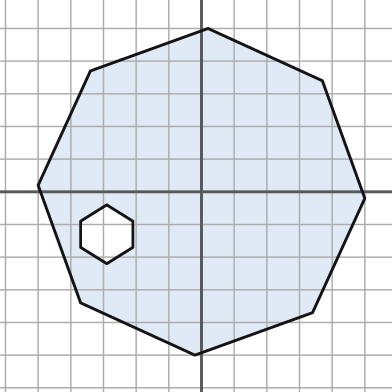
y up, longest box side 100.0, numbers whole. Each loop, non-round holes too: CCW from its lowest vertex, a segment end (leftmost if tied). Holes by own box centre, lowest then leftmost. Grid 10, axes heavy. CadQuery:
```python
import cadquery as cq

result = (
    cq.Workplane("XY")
    .moveTo(-2.0, -50.0)
    .lineTo(34.0, -37.0)
    .lineTo(50.0, -2.0)
    .lineTo(37.0, 34.0)
    .lineTo(2.0, 50.0)
    .lineTo(-34.0, 37.0)
    .lineTo(-50.0, 2.0)
    .lineTo(-37.0, -34.0)
    .close()
    .moveTo(-29.0, -22.0)
    .lineTo(-21.0, -17.0)
    .lineTo(-21.0, -9.0)
    .lineTo(-29.0, -4.0)
    .lineTo(-37.0, -9.0)
    .lineTo(-37.0, -17.0)
    .close()
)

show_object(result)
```